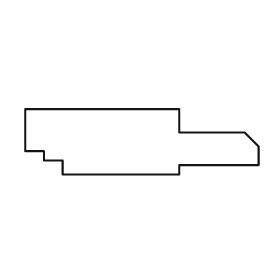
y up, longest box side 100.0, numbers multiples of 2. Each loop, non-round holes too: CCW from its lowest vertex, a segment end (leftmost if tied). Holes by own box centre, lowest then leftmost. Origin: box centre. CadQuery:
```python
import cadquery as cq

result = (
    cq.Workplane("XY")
    .moveTo(-34.0, -14.0)
    .lineTo(16.0, -14.0)
    .lineTo(16.0, -10.0)
    .lineTo(50.0, -10.0)
    .lineTo(50.0, -2.0)
    .lineTo(44.0, 4.0)
    .lineTo(16.0, 4.0)
    .lineTo(16.0, 14.0)
    .lineTo(-50.0, 14.0)
    .lineTo(-50.0, -4.0)
    .lineTo(-42.0, -4.0)
    .lineTo(-42.0, -8.0)
    .lineTo(-34.0, -8.0)
    .close()
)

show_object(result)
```